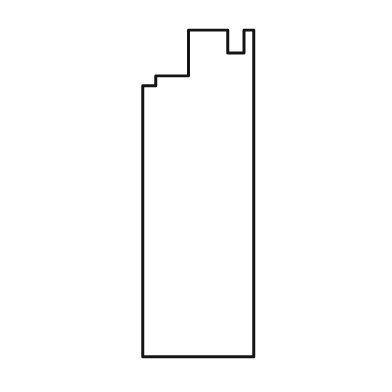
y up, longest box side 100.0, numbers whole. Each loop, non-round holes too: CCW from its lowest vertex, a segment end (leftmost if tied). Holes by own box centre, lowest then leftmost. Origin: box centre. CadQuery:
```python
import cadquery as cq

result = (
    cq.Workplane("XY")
    .moveTo(-17.0, -50.0)
    .lineTo(17.0, -50.0)
    .lineTo(17.0, 50.0)
    .lineTo(14.0, 50.0)
    .lineTo(14.0, 43.0)
    .lineTo(9.0, 43.0)
    .lineTo(9.0, 50.0)
    .lineTo(-3.0, 50.0)
    .lineTo(-3.0, 36.0)
    .lineTo(-13.0, 36.0)
    .lineTo(-13.0, 33.0)
    .lineTo(-17.0, 33.0)
    .close()
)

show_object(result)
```